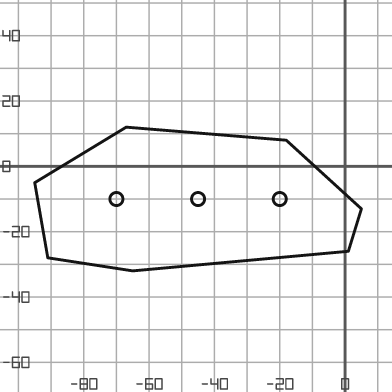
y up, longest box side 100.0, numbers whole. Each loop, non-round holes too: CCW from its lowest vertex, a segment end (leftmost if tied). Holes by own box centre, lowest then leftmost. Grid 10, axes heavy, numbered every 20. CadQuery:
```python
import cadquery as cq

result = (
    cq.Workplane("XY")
    .moveTo(-65.0, -32.0)
    .lineTo(1.0, -26.0)
    .lineTo(5.0, -13.0)
    .lineTo(-18.0, 8.0)
    .lineTo(-67.0, 12.0)
    .lineTo(-95.0, -5.0)
    .lineTo(-91.0, -28.0)
    .close()
    .moveTo(-70.0, -10.0)
    .circle(2.0)
    .moveTo(-45.0, -10.0)
    .circle(2.0)
    .moveTo(-20.0, -10.0)
    .circle(2.0)
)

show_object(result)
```